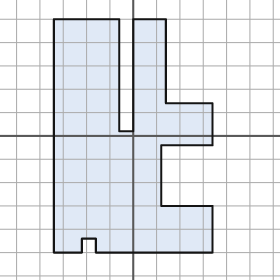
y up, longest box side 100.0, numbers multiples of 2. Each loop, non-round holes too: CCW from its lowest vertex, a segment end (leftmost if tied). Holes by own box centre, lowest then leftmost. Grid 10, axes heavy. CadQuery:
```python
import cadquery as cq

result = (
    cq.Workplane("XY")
    .moveTo(-34.0, -50.0)
    .lineTo(-22.0, -50.0)
    .lineTo(-22.0, -44.0)
    .lineTo(-16.0, -44.0)
    .lineTo(-16.0, -50.0)
    .lineTo(34.0, -50.0)
    .lineTo(34.0, -30.0)
    .lineTo(12.0, -30.0)
    .lineTo(12.0, -4.0)
    .lineTo(34.0, -4.0)
    .lineTo(34.0, 14.0)
    .lineTo(14.0, 14.0)
    .lineTo(14.0, 50.0)
    .lineTo(0.0, 50.0)
    .lineTo(0.0, 2.0)
    .lineTo(-6.0, 2.0)
    .lineTo(-6.0, 50.0)
    .lineTo(-34.0, 50.0)
    .close()
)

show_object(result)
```